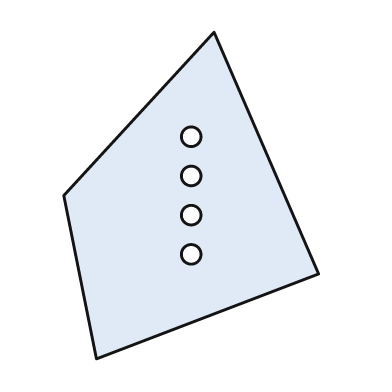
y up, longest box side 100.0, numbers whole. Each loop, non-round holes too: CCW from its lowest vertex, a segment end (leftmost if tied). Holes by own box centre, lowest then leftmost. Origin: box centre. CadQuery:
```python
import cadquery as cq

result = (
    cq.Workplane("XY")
    .moveTo(-29.0, -50.0)
    .lineTo(39.0, -24.0)
    .lineTo(7.0, 50.0)
    .lineTo(-39.0, 0.0)
    .close()
    .moveTo(0.0, -18.0)
    .circle(3.0)
    .moveTo(0.0, -6.0)
    .circle(3.0)
    .moveTo(0.0, 6.0)
    .circle(3.0)
    .moveTo(0.0, 18.0)
    .circle(3.0)
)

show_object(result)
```